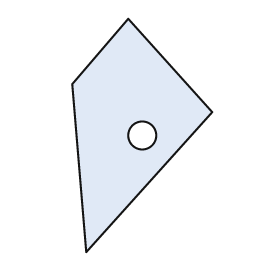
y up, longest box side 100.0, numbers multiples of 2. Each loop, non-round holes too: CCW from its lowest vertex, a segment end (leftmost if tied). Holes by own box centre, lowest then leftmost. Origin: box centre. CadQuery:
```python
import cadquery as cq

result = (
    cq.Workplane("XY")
    .moveTo(-24.0, -50.0)
    .lineTo(30.0, 10.0)
    .lineTo(-6.0, 50.0)
    .lineTo(-30.0, 22.0)
    .close()
    .moveTo(0.0, 0.0)
    .circle(6.0)
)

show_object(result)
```